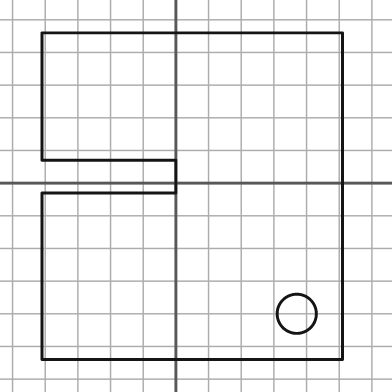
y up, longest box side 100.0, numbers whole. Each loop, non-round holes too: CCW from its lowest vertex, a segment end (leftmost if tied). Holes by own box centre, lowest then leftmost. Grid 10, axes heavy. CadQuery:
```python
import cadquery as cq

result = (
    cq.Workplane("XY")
    .moveTo(-41.0, -54.0)
    .lineTo(51.0, -54.0)
    .lineTo(51.0, 46.0)
    .lineTo(-41.0, 46.0)
    .lineTo(-41.0, 7.0)
    .lineTo(0.0, 7.0)
    .lineTo(0.0, -3.0)
    .lineTo(-41.0, -3.0)
    .close()
    .moveTo(37.0, -40.0)
    .circle(6.0)
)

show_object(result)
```